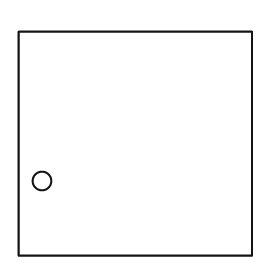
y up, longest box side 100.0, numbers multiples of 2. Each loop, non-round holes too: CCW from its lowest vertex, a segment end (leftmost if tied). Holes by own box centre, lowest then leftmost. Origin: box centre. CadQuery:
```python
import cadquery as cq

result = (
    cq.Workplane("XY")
    .moveTo(-50.0, -48.0)
    .lineTo(50.0, -48.0)
    .lineTo(50.0, 48.0)
    .lineTo(-50.0, 48.0)
    .close()
    .moveTo(-40.0, -16.0)
    .circle(4.0)
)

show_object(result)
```